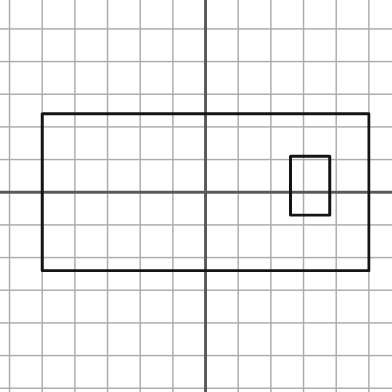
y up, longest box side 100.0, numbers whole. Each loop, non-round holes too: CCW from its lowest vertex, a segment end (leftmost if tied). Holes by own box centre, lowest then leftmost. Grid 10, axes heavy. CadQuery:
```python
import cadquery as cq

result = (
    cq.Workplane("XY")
    .moveTo(-50.0, -24.0)
    .lineTo(50.0, -24.0)
    .lineTo(50.0, 24.0)
    .lineTo(-50.0, 24.0)
    .close()
    .moveTo(26.0, -7.0)
    .lineTo(38.0, -7.0)
    .lineTo(38.0, 11.0)
    .lineTo(26.0, 11.0)
    .close()
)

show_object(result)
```